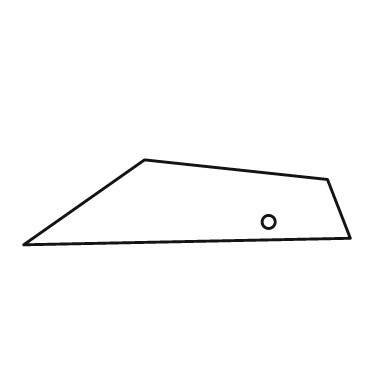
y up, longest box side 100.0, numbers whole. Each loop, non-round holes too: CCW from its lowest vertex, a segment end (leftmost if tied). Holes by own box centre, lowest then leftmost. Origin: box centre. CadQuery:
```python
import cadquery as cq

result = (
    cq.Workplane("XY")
    .moveTo(-50.0, -13.0)
    .lineTo(50.0, -11.0)
    .lineTo(43.0, 7.0)
    .lineTo(-13.0, 13.0)
    .close()
    .moveTo(25.0, -6.0)
    .circle(2.0)
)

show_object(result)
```